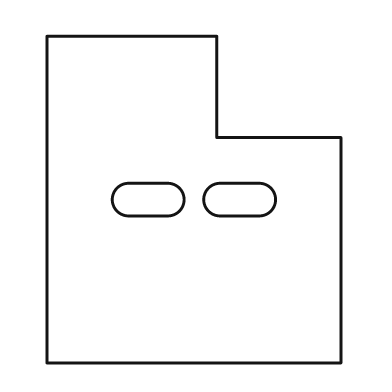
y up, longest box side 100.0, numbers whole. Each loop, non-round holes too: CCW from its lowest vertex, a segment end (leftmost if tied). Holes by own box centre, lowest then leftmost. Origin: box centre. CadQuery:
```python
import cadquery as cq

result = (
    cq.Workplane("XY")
    .moveTo(-45.0, -50.0)
    .lineTo(45.0, -50.0)
    .lineTo(45.0, 19.0)
    .lineTo(7.0, 19.0)
    .lineTo(7.0, 50.0)
    .lineTo(-45.0, 50.0)
    .close()
    .moveTo(-20.0, -5.0)
    .lineTo(-8.0, -5.0)
    .threePointArc((-3.0, 0.0), (-8.0, 5.0))
    .lineTo(-20.0, 5.0)
    .threePointArc((-25.0, 0.0), (-20.0, -5.0))
    .close()
    .moveTo(8.0, -5.0)
    .lineTo(20.0, -5.0)
    .threePointArc((25.0, 0.0), (20.0, 5.0))
    .lineTo(8.0, 5.0)
    .threePointArc((3.0, 0.0), (8.0, -5.0))
    .close()
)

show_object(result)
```